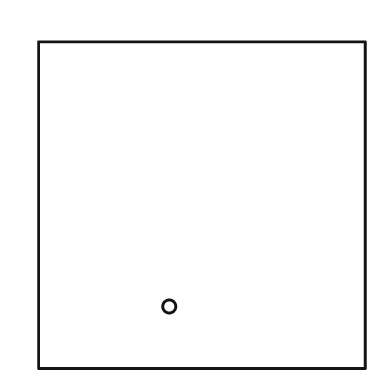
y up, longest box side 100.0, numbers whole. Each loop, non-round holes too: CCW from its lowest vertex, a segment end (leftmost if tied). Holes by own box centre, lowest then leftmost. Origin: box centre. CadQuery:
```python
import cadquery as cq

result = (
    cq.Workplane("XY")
    .moveTo(-50.0, -50.0)
    .lineTo(50.0, -50.0)
    .lineTo(50.0, 50.0)
    .lineTo(-50.0, 50.0)
    .close()
    .moveTo(-10.0, -31.0)
    .circle(2.0)
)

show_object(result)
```